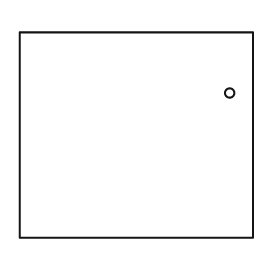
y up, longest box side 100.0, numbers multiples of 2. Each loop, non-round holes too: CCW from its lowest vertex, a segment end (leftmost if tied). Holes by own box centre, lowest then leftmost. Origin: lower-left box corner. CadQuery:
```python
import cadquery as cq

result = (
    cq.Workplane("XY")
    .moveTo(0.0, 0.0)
    .lineTo(100.0, 0.0)
    .lineTo(100.0, 88.0)
    .lineTo(0.0, 88.0)
    .close()
    .moveTo(90.0, 62.0)
    .circle(2.0)
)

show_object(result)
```